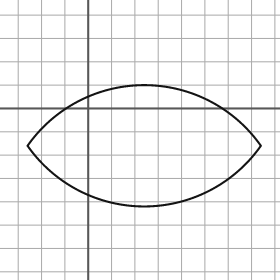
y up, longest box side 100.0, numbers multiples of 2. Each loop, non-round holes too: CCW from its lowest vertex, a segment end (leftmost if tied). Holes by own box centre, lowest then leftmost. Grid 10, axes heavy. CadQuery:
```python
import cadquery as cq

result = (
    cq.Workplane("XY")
    .moveTo(-26.0, -16.0)
    .threePointArc((24.0, -42.0), (74.0, -16.0))
    .threePointArc((24.0, 10.0), (-26.0, -16.0))
    .close()
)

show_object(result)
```